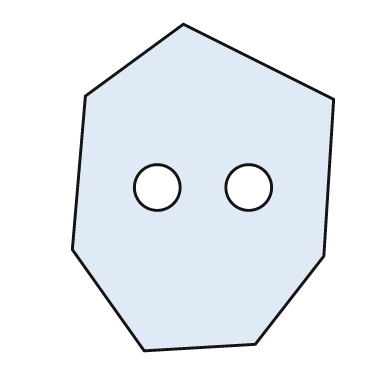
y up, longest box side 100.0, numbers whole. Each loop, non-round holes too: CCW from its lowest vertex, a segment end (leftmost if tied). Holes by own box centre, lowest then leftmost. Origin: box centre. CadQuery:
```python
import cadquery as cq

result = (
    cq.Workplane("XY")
    .moveTo(-18.0, -50.0)
    .lineTo(16.0, -48.0)
    .lineTo(37.0, -21.0)
    .lineTo(40.0, 27.0)
    .lineTo(-6.0, 50.0)
    .lineTo(-36.0, 28.0)
    .lineTo(-40.0, -19.0)
    .close()
    .moveTo(-14.0, 0.0)
    .circle(7.0)
    .moveTo(14.0, 0.0)
    .circle(7.0)
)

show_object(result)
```